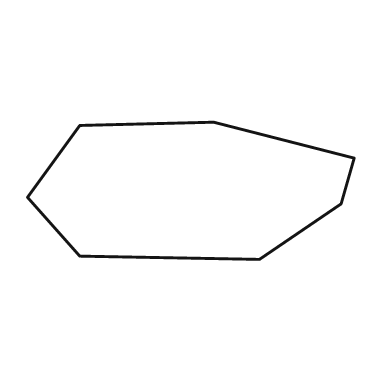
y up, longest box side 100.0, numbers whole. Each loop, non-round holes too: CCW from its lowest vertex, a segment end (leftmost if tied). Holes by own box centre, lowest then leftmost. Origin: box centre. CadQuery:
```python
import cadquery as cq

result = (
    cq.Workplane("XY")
    .moveTo(21.0, -21.0)
    .lineTo(46.0, -4.0)
    .lineTo(50.0, 10.0)
    .lineTo(7.0, 21.0)
    .lineTo(-34.0, 20.0)
    .lineTo(-50.0, -2.0)
    .lineTo(-34.0, -20.0)
    .close()
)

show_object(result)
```